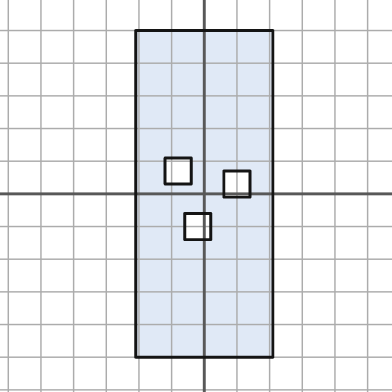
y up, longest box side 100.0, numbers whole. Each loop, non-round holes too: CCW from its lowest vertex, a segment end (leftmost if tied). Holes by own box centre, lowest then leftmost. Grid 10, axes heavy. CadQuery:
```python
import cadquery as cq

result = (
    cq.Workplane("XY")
    .moveTo(-21.0, -50.0)
    .lineTo(21.0, -50.0)
    .lineTo(21.0, 50.0)
    .lineTo(-21.0, 50.0)
    .close()
    .moveTo(-6.0, -14.0)
    .lineTo(2.0, -14.0)
    .lineTo(2.0, -6.0)
    .lineTo(-6.0, -6.0)
    .close()
    .moveTo(6.0, -1.0)
    .lineTo(14.0, -1.0)
    .lineTo(14.0, 7.0)
    .lineTo(6.0, 7.0)
    .close()
    .moveTo(-12.0, 3.0)
    .lineTo(-4.0, 3.0)
    .lineTo(-4.0, 11.0)
    .lineTo(-12.0, 11.0)
    .close()
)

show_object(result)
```